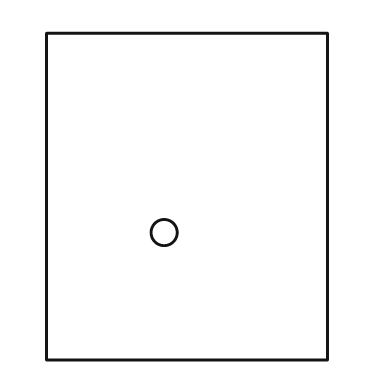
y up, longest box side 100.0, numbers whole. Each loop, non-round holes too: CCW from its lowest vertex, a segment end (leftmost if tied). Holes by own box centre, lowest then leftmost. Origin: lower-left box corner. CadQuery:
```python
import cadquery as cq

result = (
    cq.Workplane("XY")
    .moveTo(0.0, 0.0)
    .lineTo(86.0, 0.0)
    .lineTo(86.0, 100.0)
    .lineTo(0.0, 100.0)
    .close()
    .moveTo(36.0, 39.0)
    .circle(4.0)
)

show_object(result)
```